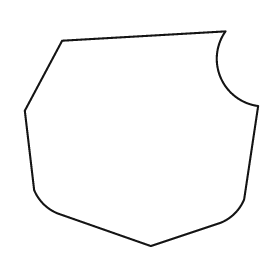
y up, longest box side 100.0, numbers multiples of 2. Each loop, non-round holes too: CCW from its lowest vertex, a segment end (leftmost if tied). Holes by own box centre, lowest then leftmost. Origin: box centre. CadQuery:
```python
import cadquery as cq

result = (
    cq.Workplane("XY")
    .moveTo(4.0, -46.0)
    .lineTo(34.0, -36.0)
    .threePointArc((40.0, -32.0), (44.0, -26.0))
    .lineTo(50.0, 14.0)
    .threePointArc((34.0, 26.0), (36.0, 46.0))
    .lineTo(-34.0, 42.0)
    .lineTo(-50.0, 12.0)
    .lineTo(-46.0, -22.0)
    .threePointArc((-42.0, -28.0), (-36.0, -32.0))
    .close()
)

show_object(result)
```